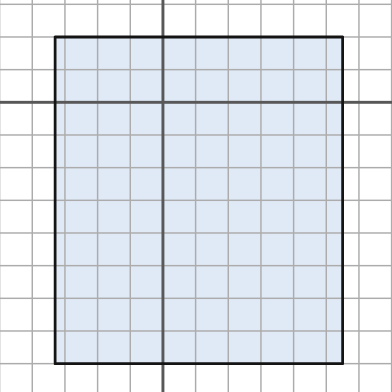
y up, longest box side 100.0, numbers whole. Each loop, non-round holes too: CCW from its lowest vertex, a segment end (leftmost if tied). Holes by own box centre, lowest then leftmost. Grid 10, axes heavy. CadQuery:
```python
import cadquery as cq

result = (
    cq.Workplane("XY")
    .moveTo(-33.0, -80.0)
    .lineTo(55.0, -80.0)
    .lineTo(55.0, 20.0)
    .lineTo(-33.0, 20.0)
    .close()
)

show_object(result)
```